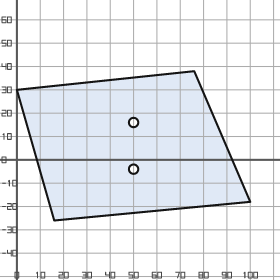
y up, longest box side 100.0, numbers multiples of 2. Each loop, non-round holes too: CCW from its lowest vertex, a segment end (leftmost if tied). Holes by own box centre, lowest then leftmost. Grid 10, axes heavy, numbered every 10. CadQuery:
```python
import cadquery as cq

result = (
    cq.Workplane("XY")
    .moveTo(16.0, -26.0)
    .lineTo(100.0, -18.0)
    .lineTo(76.0, 38.0)
    .lineTo(0.0, 30.0)
    .close()
    .moveTo(50.0, -4.0)
    .circle(2.0)
    .moveTo(50.0, 16.0)
    .circle(2.0)
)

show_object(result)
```